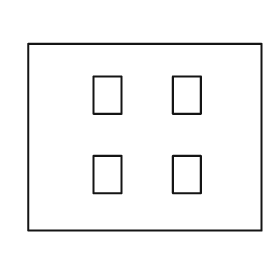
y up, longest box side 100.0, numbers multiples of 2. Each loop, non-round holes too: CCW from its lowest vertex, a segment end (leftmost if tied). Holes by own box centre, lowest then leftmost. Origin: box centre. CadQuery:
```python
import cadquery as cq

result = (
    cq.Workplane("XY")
    .moveTo(-50.0, -40.0)
    .lineTo(50.0, -40.0)
    .lineTo(50.0, 40.0)
    .lineTo(-50.0, 40.0)
    .close()
    .moveTo(-22.0, -24.0)
    .lineTo(-10.0, -24.0)
    .lineTo(-10.0, -8.0)
    .lineTo(-22.0, -8.0)
    .close()
    .moveTo(12.0, -24.0)
    .lineTo(24.0, -24.0)
    .lineTo(24.0, -8.0)
    .lineTo(12.0, -8.0)
    .close()
    .moveTo(-22.0, 10.0)
    .lineTo(-10.0, 10.0)
    .lineTo(-10.0, 26.0)
    .lineTo(-22.0, 26.0)
    .close()
    .moveTo(12.0, 10.0)
    .lineTo(24.0, 10.0)
    .lineTo(24.0, 26.0)
    .lineTo(12.0, 26.0)
    .close()
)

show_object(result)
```